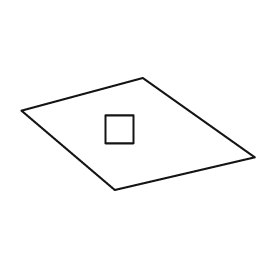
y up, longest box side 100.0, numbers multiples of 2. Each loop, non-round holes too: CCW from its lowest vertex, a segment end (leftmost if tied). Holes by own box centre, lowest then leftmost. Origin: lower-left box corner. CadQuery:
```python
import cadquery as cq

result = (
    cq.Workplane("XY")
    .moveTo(40.0, 0.0)
    .lineTo(100.0, 14.0)
    .lineTo(52.0, 48.0)
    .lineTo(0.0, 34.0)
    .close()
    .moveTo(36.0, 20.0)
    .lineTo(48.0, 20.0)
    .lineTo(48.0, 32.0)
    .lineTo(36.0, 32.0)
    .close()
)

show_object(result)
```